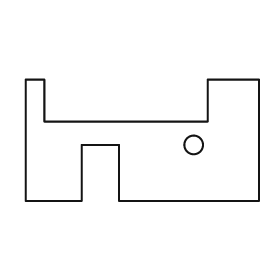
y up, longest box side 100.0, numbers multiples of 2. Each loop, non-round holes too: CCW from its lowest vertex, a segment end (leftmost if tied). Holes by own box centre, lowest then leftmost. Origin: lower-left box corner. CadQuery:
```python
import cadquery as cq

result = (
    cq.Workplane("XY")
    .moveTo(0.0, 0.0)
    .lineTo(24.0, 0.0)
    .lineTo(24.0, 24.0)
    .lineTo(40.0, 24.0)
    .lineTo(40.0, 0.0)
    .lineTo(100.0, 0.0)
    .lineTo(100.0, 52.0)
    .lineTo(78.0, 52.0)
    .lineTo(78.0, 34.0)
    .lineTo(8.0, 34.0)
    .lineTo(8.0, 52.0)
    .lineTo(0.0, 52.0)
    .close()
    .moveTo(72.0, 24.0)
    .circle(4.0)
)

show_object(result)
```